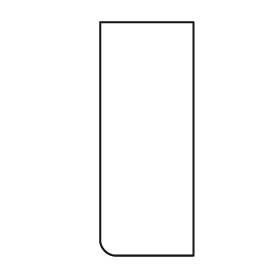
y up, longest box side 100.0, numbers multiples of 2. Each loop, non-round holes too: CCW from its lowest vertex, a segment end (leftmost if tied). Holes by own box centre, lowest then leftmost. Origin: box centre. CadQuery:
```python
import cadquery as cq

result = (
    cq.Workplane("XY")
    .moveTo(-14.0, -50.0)
    .lineTo(20.0, -50.0)
    .lineTo(20.0, 50.0)
    .lineTo(-20.0, 50.0)
    .lineTo(-20.0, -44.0)
    .threePointArc((-18.0, -48.0), (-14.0, -50.0))
    .close()
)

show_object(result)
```